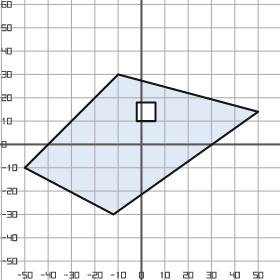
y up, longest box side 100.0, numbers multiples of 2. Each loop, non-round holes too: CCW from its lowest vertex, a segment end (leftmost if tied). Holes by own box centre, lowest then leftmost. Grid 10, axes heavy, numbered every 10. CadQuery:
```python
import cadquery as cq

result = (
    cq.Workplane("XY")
    .moveTo(-12.0, -30.0)
    .lineTo(50.0, 14.0)
    .lineTo(-10.0, 30.0)
    .lineTo(-50.0, -10.0)
    .close()
    .moveTo(-2.0, 10.0)
    .lineTo(6.0, 10.0)
    .lineTo(6.0, 18.0)
    .lineTo(-2.0, 18.0)
    .close()
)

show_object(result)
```